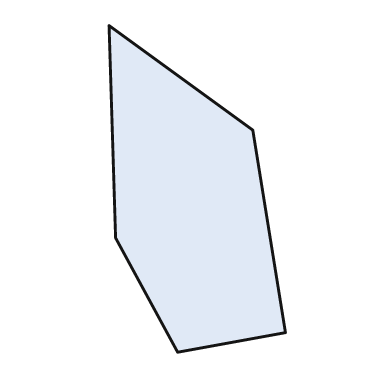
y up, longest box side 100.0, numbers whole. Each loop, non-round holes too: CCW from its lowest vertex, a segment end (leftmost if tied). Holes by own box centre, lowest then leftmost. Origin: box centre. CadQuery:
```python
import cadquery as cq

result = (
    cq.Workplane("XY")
    .moveTo(-6.0, -50.0)
    .lineTo(27.0, -44.0)
    .lineTo(17.0, 18.0)
    .lineTo(-27.0, 50.0)
    .lineTo(-25.0, -15.0)
    .close()
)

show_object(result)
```